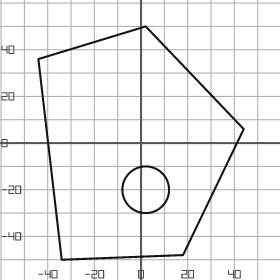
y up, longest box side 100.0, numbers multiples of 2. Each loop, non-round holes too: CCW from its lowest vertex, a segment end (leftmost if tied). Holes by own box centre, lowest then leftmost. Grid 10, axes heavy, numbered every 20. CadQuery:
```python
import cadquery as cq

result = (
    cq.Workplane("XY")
    .moveTo(-34.0, -50.0)
    .lineTo(18.0, -48.0)
    .lineTo(44.0, 6.0)
    .lineTo(2.0, 50.0)
    .lineTo(-44.0, 36.0)
    .close()
    .moveTo(2.0, -20.0)
    .circle(10.0)
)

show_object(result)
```